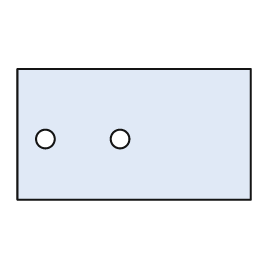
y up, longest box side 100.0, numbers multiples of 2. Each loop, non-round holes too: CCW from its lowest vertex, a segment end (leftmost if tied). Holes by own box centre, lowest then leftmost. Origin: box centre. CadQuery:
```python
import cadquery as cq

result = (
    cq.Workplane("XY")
    .moveTo(-50.0, -28.0)
    .lineTo(50.0, -28.0)
    .lineTo(50.0, 28.0)
    .lineTo(-50.0, 28.0)
    .close()
    .moveTo(-38.0, -2.0)
    .circle(4.0)
    .moveTo(-6.0, -2.0)
    .circle(4.0)
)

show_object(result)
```